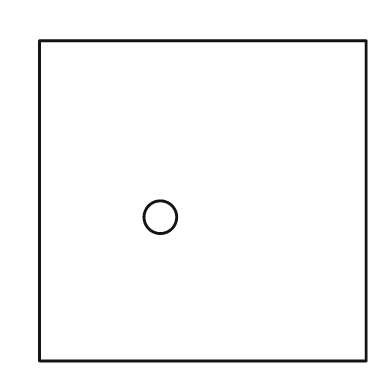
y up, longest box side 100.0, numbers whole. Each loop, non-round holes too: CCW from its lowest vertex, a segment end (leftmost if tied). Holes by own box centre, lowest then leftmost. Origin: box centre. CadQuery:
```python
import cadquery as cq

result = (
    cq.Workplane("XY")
    .moveTo(-50.0, -49.0)
    .lineTo(50.0, -49.0)
    .lineTo(50.0, 49.0)
    .lineTo(-50.0, 49.0)
    .close()
    .moveTo(-13.0, -5.0)
    .circle(5.0)
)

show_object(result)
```